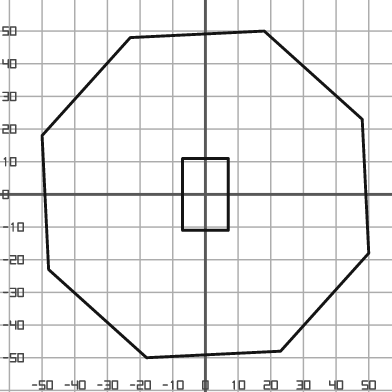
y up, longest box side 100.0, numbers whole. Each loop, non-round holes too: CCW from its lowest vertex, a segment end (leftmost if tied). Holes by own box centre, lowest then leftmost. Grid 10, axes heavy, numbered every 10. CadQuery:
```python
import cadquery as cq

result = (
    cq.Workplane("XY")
    .moveTo(-18.0, -50.0)
    .lineTo(23.0, -48.0)
    .lineTo(50.0, -18.0)
    .lineTo(48.0, 23.0)
    .lineTo(18.0, 50.0)
    .lineTo(-23.0, 48.0)
    .lineTo(-50.0, 18.0)
    .lineTo(-48.0, -23.0)
    .close()
    .moveTo(-7.0, -11.0)
    .lineTo(7.0, -11.0)
    .lineTo(7.0, 11.0)
    .lineTo(-7.0, 11.0)
    .close()
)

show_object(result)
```